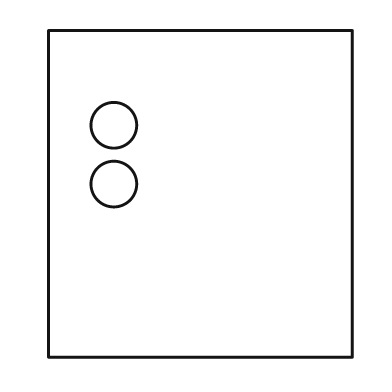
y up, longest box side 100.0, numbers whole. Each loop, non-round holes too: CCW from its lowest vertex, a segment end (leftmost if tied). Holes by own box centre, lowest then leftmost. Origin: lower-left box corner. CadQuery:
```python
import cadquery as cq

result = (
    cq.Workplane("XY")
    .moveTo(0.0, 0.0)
    .lineTo(93.0, 0.0)
    .lineTo(93.0, 100.0)
    .lineTo(0.0, 100.0)
    .close()
    .moveTo(20.0, 53.0)
    .circle(7.0)
    .moveTo(20.0, 71.0)
    .circle(7.0)
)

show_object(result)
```